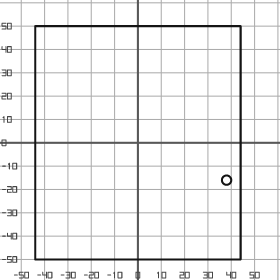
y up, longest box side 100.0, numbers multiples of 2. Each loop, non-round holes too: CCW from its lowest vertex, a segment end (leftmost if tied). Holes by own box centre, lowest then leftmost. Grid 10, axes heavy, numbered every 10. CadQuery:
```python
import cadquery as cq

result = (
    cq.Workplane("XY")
    .moveTo(-44.0, -50.0)
    .lineTo(44.0, -50.0)
    .lineTo(44.0, 50.0)
    .lineTo(-44.0, 50.0)
    .close()
    .moveTo(38.0, -16.0)
    .circle(2.0)
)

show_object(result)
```